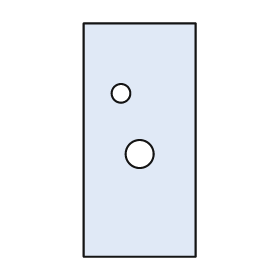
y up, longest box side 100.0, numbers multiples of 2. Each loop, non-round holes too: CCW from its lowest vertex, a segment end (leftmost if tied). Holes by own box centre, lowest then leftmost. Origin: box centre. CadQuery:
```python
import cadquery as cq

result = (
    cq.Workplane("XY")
    .moveTo(-24.0, -50.0)
    .lineTo(24.0, -50.0)
    .lineTo(24.0, 50.0)
    .lineTo(-24.0, 50.0)
    .close()
    .moveTo(0.0, -6.0)
    .circle(6.0)
    .moveTo(-8.0, 20.0)
    .circle(4.0)
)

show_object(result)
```